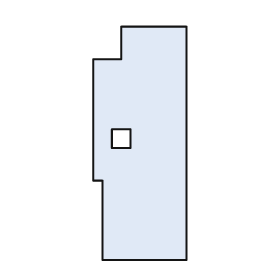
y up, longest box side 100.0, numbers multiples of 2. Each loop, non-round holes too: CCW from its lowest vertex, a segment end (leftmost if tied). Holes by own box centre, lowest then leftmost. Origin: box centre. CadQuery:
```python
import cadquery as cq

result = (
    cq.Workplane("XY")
    .moveTo(-16.0, -50.0)
    .lineTo(20.0, -50.0)
    .lineTo(20.0, 50.0)
    .lineTo(-8.0, 50.0)
    .lineTo(-8.0, 36.0)
    .lineTo(-20.0, 36.0)
    .lineTo(-20.0, -16.0)
    .lineTo(-16.0, -16.0)
    .close()
    .moveTo(-12.0, -2.0)
    .lineTo(-4.0, -2.0)
    .lineTo(-4.0, 6.0)
    .lineTo(-12.0, 6.0)
    .close()
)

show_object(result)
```